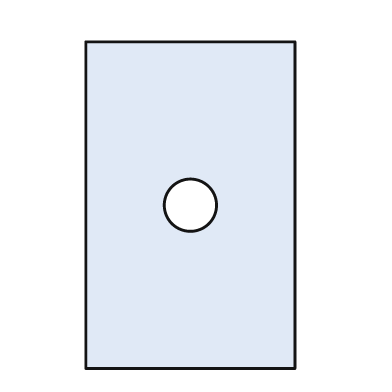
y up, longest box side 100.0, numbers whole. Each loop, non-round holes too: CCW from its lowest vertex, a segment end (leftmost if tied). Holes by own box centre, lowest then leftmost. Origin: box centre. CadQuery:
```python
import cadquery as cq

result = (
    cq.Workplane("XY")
    .moveTo(-32.0, -50.0)
    .lineTo(32.0, -50.0)
    .lineTo(32.0, 50.0)
    .lineTo(-32.0, 50.0)
    .close()
    .moveTo(0.0, 0.0)
    .circle(8.0)
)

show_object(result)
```